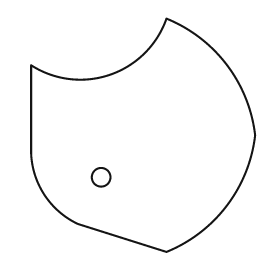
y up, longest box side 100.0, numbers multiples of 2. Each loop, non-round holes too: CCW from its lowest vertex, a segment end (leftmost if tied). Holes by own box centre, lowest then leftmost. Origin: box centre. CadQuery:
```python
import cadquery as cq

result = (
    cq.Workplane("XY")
    .moveTo(10.0, -50.0)
    .threePointArc((36.0, -30.0), (48.0, 0.0))
    .threePointArc((36.0, 30.0), (10.0, 50.0))
    .threePointArc((-14.0, 26.0), (-48.0, 30.0))
    .lineTo(-48.0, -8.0)
    .threePointArc((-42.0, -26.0), (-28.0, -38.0))
    .close()
    .moveTo(-18.0, -18.0)
    .circle(4.0)
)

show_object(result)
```